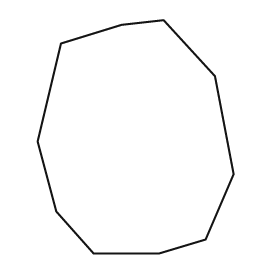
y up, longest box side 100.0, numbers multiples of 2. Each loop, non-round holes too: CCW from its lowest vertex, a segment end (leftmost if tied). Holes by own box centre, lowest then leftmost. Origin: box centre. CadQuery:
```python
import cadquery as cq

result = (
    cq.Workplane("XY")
    .moveTo(-18.0, -50.0)
    .lineTo(10.0, -50.0)
    .lineTo(30.0, -44.0)
    .lineTo(42.0, -16.0)
    .lineTo(34.0, 26.0)
    .lineTo(12.0, 50.0)
    .lineTo(-6.0, 48.0)
    .lineTo(-32.0, 40.0)
    .lineTo(-42.0, -2.0)
    .lineTo(-34.0, -32.0)
    .close()
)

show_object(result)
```